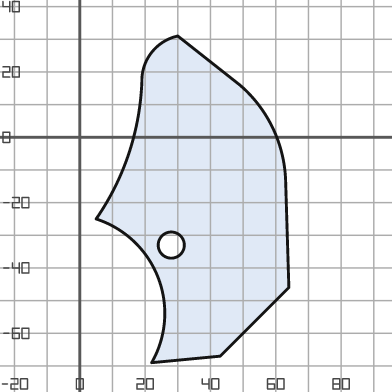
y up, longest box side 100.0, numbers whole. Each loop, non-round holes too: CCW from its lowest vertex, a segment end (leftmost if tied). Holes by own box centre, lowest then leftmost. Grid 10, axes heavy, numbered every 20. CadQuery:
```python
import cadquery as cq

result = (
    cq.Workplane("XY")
    .moveTo(22.0, -69.0)
    .lineTo(43.0, -67.0)
    .lineTo(64.0, -46.0)
    .lineTo(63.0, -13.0)
    .threePointArc((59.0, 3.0), (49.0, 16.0))
    .lineTo(30.0, 31.0)
    .threePointArc((22.0, 26.0), (19.0, 17.0))
    .threePointArc((15.0, -5.0), (5.0, -25.0))
    .threePointArc((24.0, -43.0), (22.0, -69.0))
    .close()
    .moveTo(28.0, -33.0)
    .circle(4.0)
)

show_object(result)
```